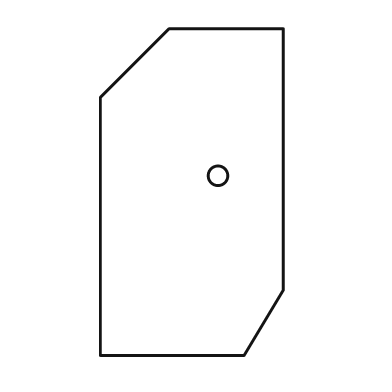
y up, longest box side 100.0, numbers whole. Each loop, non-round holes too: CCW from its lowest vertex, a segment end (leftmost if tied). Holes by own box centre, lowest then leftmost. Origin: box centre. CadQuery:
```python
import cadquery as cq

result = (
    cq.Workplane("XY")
    .moveTo(-28.0, -50.0)
    .lineTo(16.0, -50.0)
    .lineTo(28.0, -30.0)
    .lineTo(28.0, 50.0)
    .lineTo(-7.0, 50.0)
    .lineTo(-28.0, 29.0)
    .close()
    .moveTo(8.0, 5.0)
    .circle(3.0)
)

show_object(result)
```